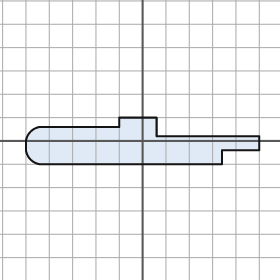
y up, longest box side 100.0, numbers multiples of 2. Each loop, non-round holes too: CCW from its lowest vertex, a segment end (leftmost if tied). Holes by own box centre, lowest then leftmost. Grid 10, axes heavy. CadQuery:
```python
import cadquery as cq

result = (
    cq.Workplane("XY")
    .moveTo(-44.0, -10.0)
    .lineTo(34.0, -10.0)
    .lineTo(34.0, -4.0)
    .lineTo(50.0, -4.0)
    .lineTo(50.0, 2.0)
    .lineTo(6.0, 2.0)
    .lineTo(6.0, 10.0)
    .lineTo(-10.0, 10.0)
    .lineTo(-10.0, 6.0)
    .lineTo(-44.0, 6.0)
    .threePointArc((-48.0, 4.0), (-50.0, 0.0))
    .lineTo(-50.0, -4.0)
    .threePointArc((-48.0, -8.0), (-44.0, -10.0))
    .close()
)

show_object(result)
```